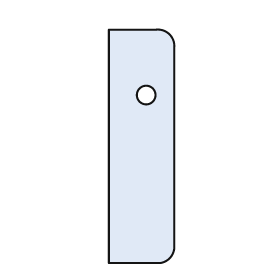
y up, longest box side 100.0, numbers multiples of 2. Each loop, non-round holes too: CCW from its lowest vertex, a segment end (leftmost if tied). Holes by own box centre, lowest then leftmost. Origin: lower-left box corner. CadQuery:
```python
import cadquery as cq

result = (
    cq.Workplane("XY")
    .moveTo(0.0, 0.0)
    .lineTo(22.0, 0.0)
    .threePointArc((26.0, 2.0), (28.0, 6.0))
    .lineTo(28.0, 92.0)
    .threePointArc((26.0, 98.0), (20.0, 100.0))
    .lineTo(0.0, 100.0)
    .close()
    .moveTo(16.0, 72.0)
    .circle(4.0)
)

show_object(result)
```